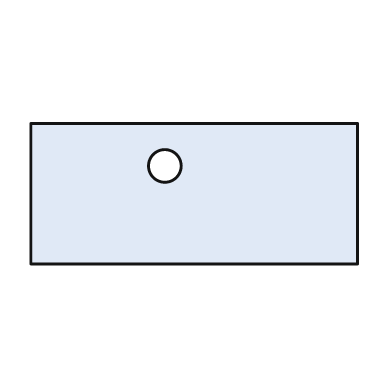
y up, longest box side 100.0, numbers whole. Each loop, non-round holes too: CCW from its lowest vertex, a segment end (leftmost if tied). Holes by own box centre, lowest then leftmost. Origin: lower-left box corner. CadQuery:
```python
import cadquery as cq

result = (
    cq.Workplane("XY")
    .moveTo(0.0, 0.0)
    .lineTo(100.0, 0.0)
    .lineTo(100.0, 43.0)
    .lineTo(0.0, 43.0)
    .close()
    .moveTo(41.0, 30.0)
    .circle(5.0)
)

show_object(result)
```